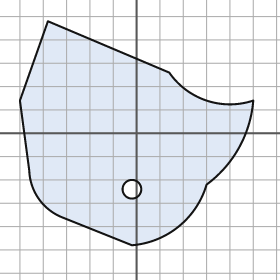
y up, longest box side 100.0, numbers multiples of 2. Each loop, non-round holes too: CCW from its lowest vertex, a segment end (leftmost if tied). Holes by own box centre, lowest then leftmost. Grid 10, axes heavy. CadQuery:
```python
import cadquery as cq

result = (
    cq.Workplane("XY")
    .moveTo(-2.0, -48.0)
    .threePointArc((18.0, -40.0), (30.0, -22.0))
    .threePointArc((44.0, -6.0), (50.0, 14.0))
    .threePointArc((30.0, 14.0), (14.0, 26.0))
    .lineTo(-38.0, 48.0)
    .lineTo(-50.0, 14.0)
    .lineTo(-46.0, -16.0)
    .threePointArc((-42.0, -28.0), (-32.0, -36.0))
    .close()
    .moveTo(-2.0, -24.0)
    .circle(4.0)
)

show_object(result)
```